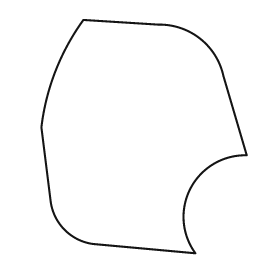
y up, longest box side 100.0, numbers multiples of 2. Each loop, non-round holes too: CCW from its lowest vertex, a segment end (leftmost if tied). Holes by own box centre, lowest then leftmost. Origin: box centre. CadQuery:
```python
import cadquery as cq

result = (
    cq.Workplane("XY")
    .moveTo(22.0, -50.0)
    .threePointArc((20.0, -22.0), (44.0, -8.0))
    .lineTo(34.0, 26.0)
    .threePointArc((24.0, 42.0), (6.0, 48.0))
    .lineTo(-26.0, 50.0)
    .threePointArc((-38.0, 28.0), (-44.0, 4.0))
    .lineTo(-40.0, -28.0)
    .threePointArc((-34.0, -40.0), (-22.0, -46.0))
    .close()
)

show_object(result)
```